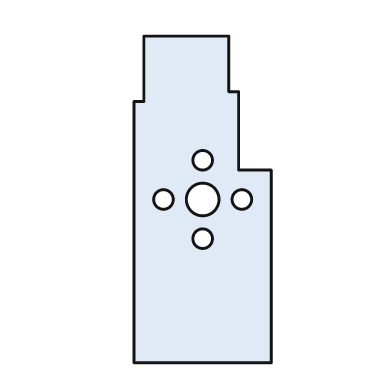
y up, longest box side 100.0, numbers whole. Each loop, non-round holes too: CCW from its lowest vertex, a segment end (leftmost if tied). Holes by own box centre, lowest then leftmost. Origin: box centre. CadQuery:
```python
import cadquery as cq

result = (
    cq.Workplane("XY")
    .moveTo(-21.0, -50.0)
    .lineTo(21.0, -50.0)
    .lineTo(21.0, 9.0)
    .lineTo(11.0, 9.0)
    .lineTo(11.0, 33.0)
    .lineTo(8.0, 33.0)
    .lineTo(8.0, 50.0)
    .lineTo(-18.0, 50.0)
    .lineTo(-18.0, 30.0)
    .lineTo(-21.0, 30.0)
    .close()
    .moveTo(0.0, -12.0)
    .circle(3.0)
    .moveTo(-12.0, 0.0)
    .circle(3.0)
    .moveTo(0.0, 0.0)
    .circle(5.0)
    .moveTo(12.0, 0.0)
    .circle(3.0)
    .moveTo(0.0, 12.0)
    .circle(3.0)
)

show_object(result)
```